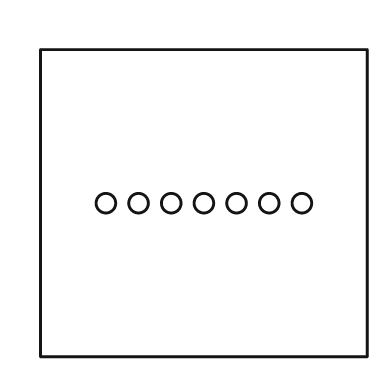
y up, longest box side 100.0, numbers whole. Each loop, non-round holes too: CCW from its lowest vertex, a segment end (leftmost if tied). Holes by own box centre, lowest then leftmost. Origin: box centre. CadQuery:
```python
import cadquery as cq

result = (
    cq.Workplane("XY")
    .moveTo(-50.0, -47.0)
    .lineTo(50.0, -47.0)
    .lineTo(50.0, 47.0)
    .lineTo(-50.0, 47.0)
    .close()
    .moveTo(-30.0, 0.0)
    .circle(3.0)
    .moveTo(-20.0, 0.0)
    .circle(3.0)
    .moveTo(-10.0, 0.0)
    .circle(3.0)
    .moveTo(0.0, 0.0)
    .circle(3.0)
    .moveTo(10.0, 0.0)
    .circle(3.0)
    .moveTo(20.0, 0.0)
    .circle(3.0)
    .moveTo(30.0, 0.0)
    .circle(3.0)
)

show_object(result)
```